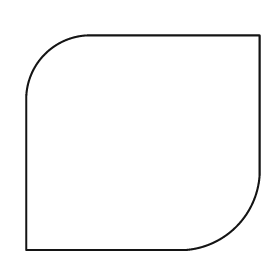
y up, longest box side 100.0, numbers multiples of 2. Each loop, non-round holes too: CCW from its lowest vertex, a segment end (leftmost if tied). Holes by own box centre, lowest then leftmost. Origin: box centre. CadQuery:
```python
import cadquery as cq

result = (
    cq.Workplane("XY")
    .moveTo(-50.0, -46.0)
    .lineTo(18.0, -46.0)
    .threePointArc((40.0, -36.0), (50.0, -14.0))
    .lineTo(50.0, 46.0)
    .lineTo(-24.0, 46.0)
    .threePointArc((-42.0, 38.0), (-50.0, 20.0))
    .close()
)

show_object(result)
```